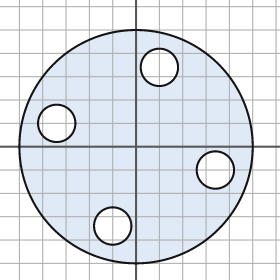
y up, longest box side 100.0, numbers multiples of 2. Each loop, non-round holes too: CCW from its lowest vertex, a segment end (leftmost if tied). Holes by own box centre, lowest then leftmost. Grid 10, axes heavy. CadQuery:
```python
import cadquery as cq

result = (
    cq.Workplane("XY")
    .moveTo(0.0, 0.0)
    .circle(50.0)
    .moveTo(-10.0, -34.0)
    .circle(8.0)
    .moveTo(34.0, -10.0)
    .circle(8.0)
    .moveTo(-34.0, 10.0)
    .circle(8.0)
    .moveTo(10.0, 34.0)
    .circle(8.0)
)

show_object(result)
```